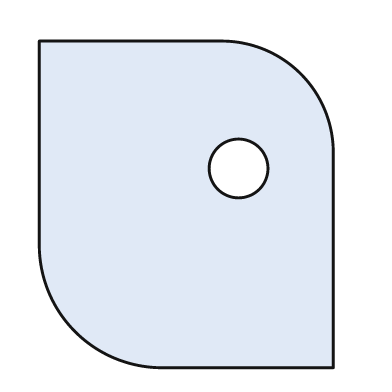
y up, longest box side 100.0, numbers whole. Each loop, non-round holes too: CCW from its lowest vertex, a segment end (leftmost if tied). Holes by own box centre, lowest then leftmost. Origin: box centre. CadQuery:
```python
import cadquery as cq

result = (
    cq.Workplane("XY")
    .moveTo(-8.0, -50.0)
    .lineTo(45.0, -50.0)
    .lineTo(45.0, 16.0)
    .threePointArc((35.0, 40.0), (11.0, 50.0))
    .lineTo(-45.0, 50.0)
    .lineTo(-45.0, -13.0)
    .threePointArc((-34.0, -39.0), (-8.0, -50.0))
    .close()
    .moveTo(16.0, 11.0)
    .circle(9.0)
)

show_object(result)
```